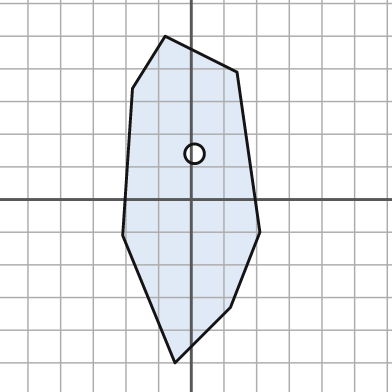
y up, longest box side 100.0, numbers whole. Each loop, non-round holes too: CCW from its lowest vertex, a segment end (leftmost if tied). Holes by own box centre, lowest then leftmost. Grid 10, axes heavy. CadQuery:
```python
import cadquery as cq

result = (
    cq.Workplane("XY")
    .moveTo(-5.0, -50.0)
    .lineTo(12.0, -33.0)
    .lineTo(21.0, -10.0)
    .lineTo(14.0, 39.0)
    .lineTo(-8.0, 50.0)
    .lineTo(-18.0, 34.0)
    .lineTo(-21.0, -11.0)
    .close()
    .moveTo(1.0, 14.0)
    .circle(3.0)
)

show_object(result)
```